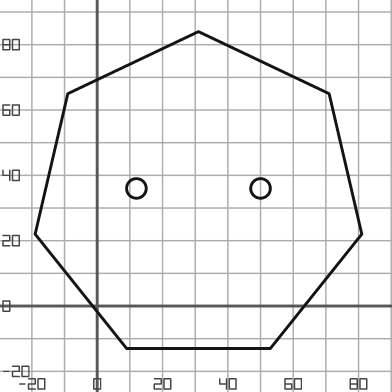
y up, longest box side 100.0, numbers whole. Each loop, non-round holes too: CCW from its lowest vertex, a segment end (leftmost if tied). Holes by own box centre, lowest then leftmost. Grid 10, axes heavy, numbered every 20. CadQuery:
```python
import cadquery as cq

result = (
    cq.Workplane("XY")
    .moveTo(9.0, -13.0)
    .lineTo(53.0, -13.0)
    .lineTo(81.0, 22.0)
    .lineTo(71.0, 65.0)
    .lineTo(31.0, 84.0)
    .lineTo(-9.0, 65.0)
    .lineTo(-19.0, 22.0)
    .close()
    .moveTo(12.0, 36.0)
    .circle(3.0)
    .moveTo(50.0, 36.0)
    .circle(3.0)
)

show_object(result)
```